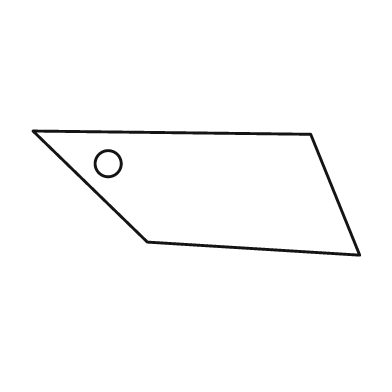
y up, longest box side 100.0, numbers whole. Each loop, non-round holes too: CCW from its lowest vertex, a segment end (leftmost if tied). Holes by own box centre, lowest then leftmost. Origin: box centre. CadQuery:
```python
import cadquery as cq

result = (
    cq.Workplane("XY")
    .moveTo(50.0, -19.0)
    .lineTo(35.0, 18.0)
    .lineTo(-50.0, 19.0)
    .lineTo(-15.0, -15.0)
    .close()
    .moveTo(-27.0, 9.0)
    .circle(4.0)
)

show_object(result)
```